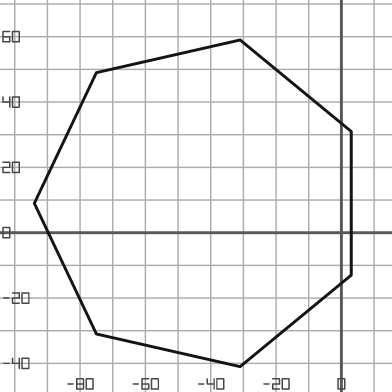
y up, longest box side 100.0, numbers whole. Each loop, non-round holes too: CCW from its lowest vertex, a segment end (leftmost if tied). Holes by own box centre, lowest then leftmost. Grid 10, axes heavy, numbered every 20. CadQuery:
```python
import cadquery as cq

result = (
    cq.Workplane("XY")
    .moveTo(-31.0, -41.0)
    .lineTo(3.0, -13.0)
    .lineTo(3.0, 31.0)
    .lineTo(-31.0, 59.0)
    .lineTo(-75.0, 49.0)
    .lineTo(-94.0, 9.0)
    .lineTo(-75.0, -31.0)
    .close()
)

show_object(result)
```